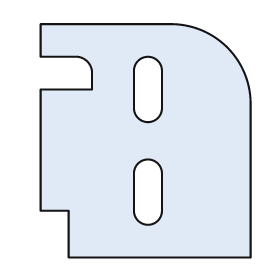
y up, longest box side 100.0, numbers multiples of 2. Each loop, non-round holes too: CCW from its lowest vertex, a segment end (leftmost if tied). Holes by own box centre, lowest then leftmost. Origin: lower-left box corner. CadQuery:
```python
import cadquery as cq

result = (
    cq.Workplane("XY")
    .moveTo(12.0, 0.0)
    .lineTo(90.0, 0.0)
    .lineTo(90.0, 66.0)
    .threePointArc((80.0, 90.0), (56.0, 100.0))
    .lineTo(0.0, 100.0)
    .lineTo(0.0, 86.0)
    .lineTo(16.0, 86.0)
    .threePointArc((20.0, 84.0), (22.0, 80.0))
    .lineTo(22.0, 72.0)
    .lineTo(0.0, 72.0)
    .lineTo(0.0, 20.0)
    .lineTo(12.0, 20.0)
    .close()
    .moveTo(40.0, 20.0)
    .threePointArc((46.0, 14.0), (52.0, 20.0))
    .lineTo(52.0, 36.0)
    .threePointArc((46.0, 42.0), (40.0, 36.0))
    .close()
    .moveTo(40.0, 64.0)
    .threePointArc((46.0, 58.0), (52.0, 64.0))
    .lineTo(52.0, 80.0)
    .threePointArc((46.0, 86.0), (40.0, 80.0))
    .close()
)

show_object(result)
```